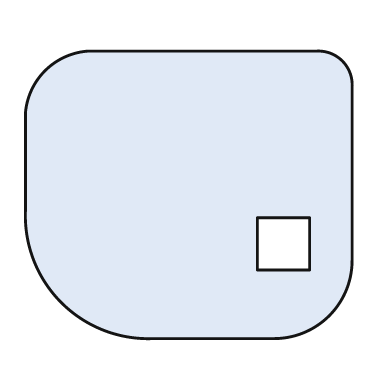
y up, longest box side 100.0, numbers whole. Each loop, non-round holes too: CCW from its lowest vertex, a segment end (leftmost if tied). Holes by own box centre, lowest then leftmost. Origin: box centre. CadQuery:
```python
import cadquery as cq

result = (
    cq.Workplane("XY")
    .moveTo(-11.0, -44.0)
    .lineTo(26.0, -44.0)
    .threePointArc((43.0, -37.0), (50.0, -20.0))
    .lineTo(50.0, 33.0)
    .threePointArc((47.0, 41.0), (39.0, 44.0))
    .lineTo(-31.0, 44.0)
    .threePointArc((-44.0, 38.0), (-50.0, 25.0))
    .lineTo(-50.0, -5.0)
    .threePointArc((-39.0, -33.0), (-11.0, -44.0))
    .close()
    .moveTo(21.0, -23.0)
    .lineTo(37.0, -23.0)
    .lineTo(37.0, -7.0)
    .lineTo(21.0, -7.0)
    .close()
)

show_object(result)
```